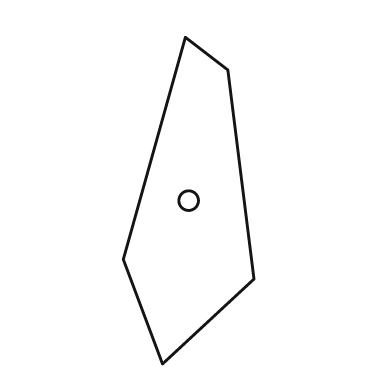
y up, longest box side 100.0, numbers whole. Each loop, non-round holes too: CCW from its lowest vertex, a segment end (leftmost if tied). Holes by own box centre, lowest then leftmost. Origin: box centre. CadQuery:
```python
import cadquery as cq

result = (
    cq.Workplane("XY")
    .moveTo(-8.0, -50.0)
    .lineTo(20.0, -24.0)
    .lineTo(12.0, 40.0)
    .lineTo(-1.0, 50.0)
    .lineTo(-20.0, -18.0)
    .close()
    .moveTo(0.0, 0.0)
    .circle(3.0)
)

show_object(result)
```